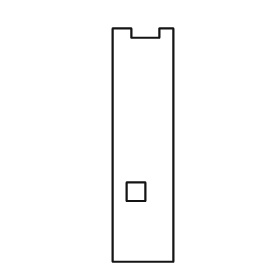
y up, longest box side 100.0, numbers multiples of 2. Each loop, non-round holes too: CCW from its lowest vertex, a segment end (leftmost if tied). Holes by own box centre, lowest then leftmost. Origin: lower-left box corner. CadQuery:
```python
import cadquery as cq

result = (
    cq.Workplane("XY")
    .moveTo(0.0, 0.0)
    .lineTo(26.0, 0.0)
    .lineTo(26.0, 100.0)
    .lineTo(20.0, 100.0)
    .lineTo(20.0, 96.0)
    .lineTo(8.0, 96.0)
    .lineTo(8.0, 100.0)
    .lineTo(0.0, 100.0)
    .close()
    .moveTo(6.0, 26.0)
    .lineTo(14.0, 26.0)
    .lineTo(14.0, 34.0)
    .lineTo(6.0, 34.0)
    .close()
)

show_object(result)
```